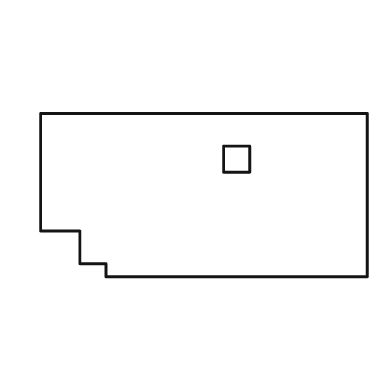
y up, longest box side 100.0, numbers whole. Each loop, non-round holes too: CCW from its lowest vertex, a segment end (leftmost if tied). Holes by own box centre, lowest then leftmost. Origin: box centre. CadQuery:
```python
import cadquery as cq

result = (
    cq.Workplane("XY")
    .moveTo(-30.0, -25.0)
    .lineTo(50.0, -25.0)
    .lineTo(50.0, 25.0)
    .lineTo(-50.0, 25.0)
    .lineTo(-50.0, -11.0)
    .lineTo(-38.0, -11.0)
    .lineTo(-38.0, -21.0)
    .lineTo(-30.0, -21.0)
    .close()
    .moveTo(6.0, 7.0)
    .lineTo(14.0, 7.0)
    .lineTo(14.0, 15.0)
    .lineTo(6.0, 15.0)
    .close()
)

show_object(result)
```